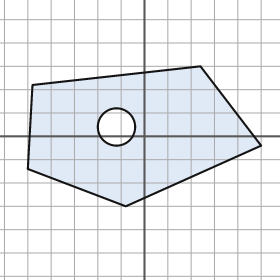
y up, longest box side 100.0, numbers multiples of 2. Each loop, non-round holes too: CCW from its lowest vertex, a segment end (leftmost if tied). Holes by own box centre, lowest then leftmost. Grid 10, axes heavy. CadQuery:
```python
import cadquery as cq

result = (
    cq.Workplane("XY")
    .moveTo(-8.0, -30.0)
    .lineTo(50.0, -4.0)
    .lineTo(24.0, 30.0)
    .lineTo(-48.0, 22.0)
    .lineTo(-50.0, -14.0)
    .close()
    .moveTo(-12.0, 4.0)
    .circle(8.0)
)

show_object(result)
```